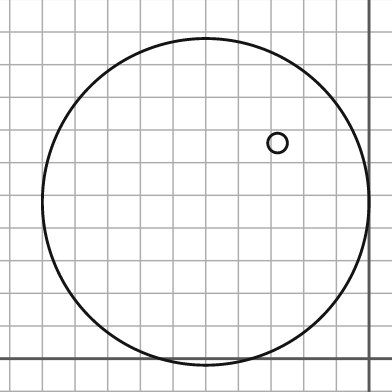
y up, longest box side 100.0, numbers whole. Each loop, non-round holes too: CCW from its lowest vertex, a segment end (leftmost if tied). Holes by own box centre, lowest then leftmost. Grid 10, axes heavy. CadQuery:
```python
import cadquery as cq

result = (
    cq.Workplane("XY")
    .moveTo(-50.0, 48.0)
    .circle(50.0)
    .moveTo(-28.0, 66.0)
    .circle(3.0)
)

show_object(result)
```